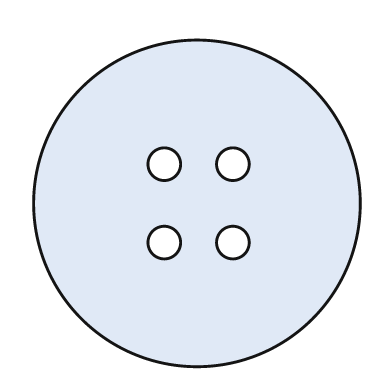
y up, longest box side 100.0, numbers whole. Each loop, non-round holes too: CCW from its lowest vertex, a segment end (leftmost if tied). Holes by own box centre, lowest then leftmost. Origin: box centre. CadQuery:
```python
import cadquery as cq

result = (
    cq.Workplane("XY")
    .moveTo(0.0, 0.0)
    .circle(50.0)
    .moveTo(-10.0, -12.0)
    .circle(5.0)
    .moveTo(11.0, -12.0)
    .circle(5.0)
    .moveTo(-10.0, 12.0)
    .circle(5.0)
    .moveTo(11.0, 12.0)
    .circle(5.0)
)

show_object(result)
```